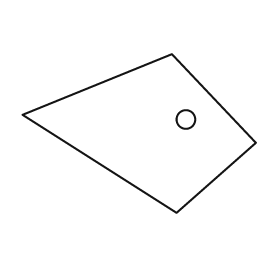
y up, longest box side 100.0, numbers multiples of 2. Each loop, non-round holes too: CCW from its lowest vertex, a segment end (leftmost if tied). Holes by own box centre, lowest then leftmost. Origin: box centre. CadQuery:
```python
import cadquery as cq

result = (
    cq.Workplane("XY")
    .moveTo(16.0, -34.0)
    .lineTo(50.0, -4.0)
    .lineTo(14.0, 34.0)
    .lineTo(-50.0, 8.0)
    .close()
    .moveTo(20.0, 6.0)
    .circle(4.0)
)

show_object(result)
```